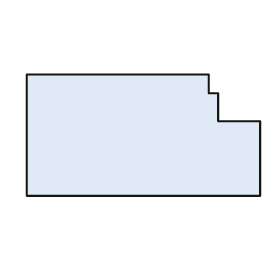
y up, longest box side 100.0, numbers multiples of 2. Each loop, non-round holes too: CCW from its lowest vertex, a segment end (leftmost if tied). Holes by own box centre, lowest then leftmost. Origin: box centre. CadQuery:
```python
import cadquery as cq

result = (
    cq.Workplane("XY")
    .moveTo(-50.0, -26.0)
    .lineTo(50.0, -26.0)
    .lineTo(50.0, 6.0)
    .lineTo(32.0, 6.0)
    .lineTo(32.0, 18.0)
    .lineTo(28.0, 18.0)
    .lineTo(28.0, 26.0)
    .lineTo(-50.0, 26.0)
    .close()
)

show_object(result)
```